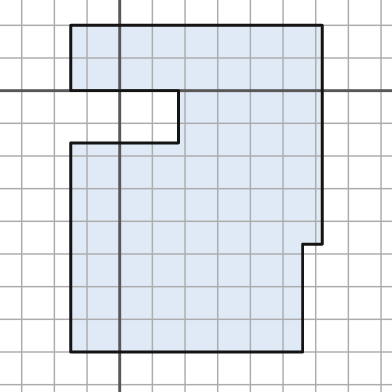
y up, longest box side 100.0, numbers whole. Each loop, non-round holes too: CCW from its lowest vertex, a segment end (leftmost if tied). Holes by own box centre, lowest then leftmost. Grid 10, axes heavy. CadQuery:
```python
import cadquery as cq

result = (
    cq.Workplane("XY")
    .moveTo(-15.0, -80.0)
    .lineTo(56.0, -80.0)
    .lineTo(56.0, -47.0)
    .lineTo(62.0, -47.0)
    .lineTo(62.0, 20.0)
    .lineTo(-15.0, 20.0)
    .lineTo(-15.0, 0.0)
    .lineTo(18.0, 0.0)
    .lineTo(18.0, -16.0)
    .lineTo(-15.0, -16.0)
    .close()
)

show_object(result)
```